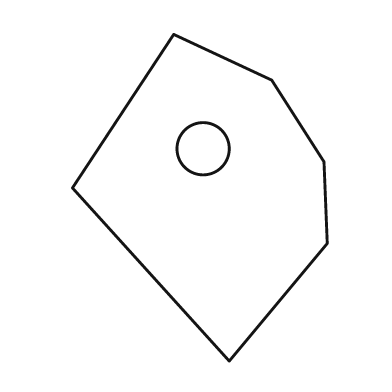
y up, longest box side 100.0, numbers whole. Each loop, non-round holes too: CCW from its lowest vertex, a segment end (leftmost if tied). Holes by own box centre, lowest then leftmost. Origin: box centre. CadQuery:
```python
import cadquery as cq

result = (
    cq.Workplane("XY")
    .moveTo(9.0, -50.0)
    .lineTo(39.0, -14.0)
    .lineTo(38.0, 11.0)
    .lineTo(22.0, 36.0)
    .lineTo(-8.0, 50.0)
    .lineTo(-39.0, 3.0)
    .close()
    .moveTo(1.0, 15.0)
    .circle(8.0)
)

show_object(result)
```